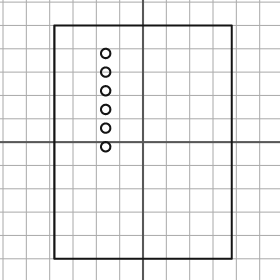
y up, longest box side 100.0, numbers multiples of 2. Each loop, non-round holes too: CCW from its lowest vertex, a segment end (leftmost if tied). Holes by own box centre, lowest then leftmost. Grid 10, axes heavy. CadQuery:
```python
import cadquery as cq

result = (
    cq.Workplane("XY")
    .moveTo(-38.0, -50.0)
    .lineTo(38.0, -50.0)
    .lineTo(38.0, 50.0)
    .lineTo(-38.0, 50.0)
    .close()
    .moveTo(-16.0, -2.0)
    .circle(2.0)
    .moveTo(-16.0, 6.0)
    .circle(2.0)
    .moveTo(-16.0, 14.0)
    .circle(2.0)
    .moveTo(-16.0, 22.0)
    .circle(2.0)
    .moveTo(-16.0, 30.0)
    .circle(2.0)
    .moveTo(-16.0, 38.0)
    .circle(2.0)
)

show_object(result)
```